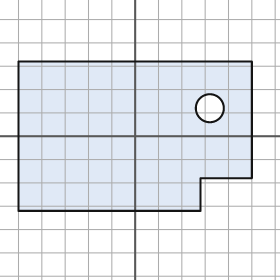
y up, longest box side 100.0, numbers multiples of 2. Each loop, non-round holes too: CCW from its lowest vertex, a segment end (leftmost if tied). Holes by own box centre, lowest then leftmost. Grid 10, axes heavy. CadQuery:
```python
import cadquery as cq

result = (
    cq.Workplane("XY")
    .moveTo(-50.0, -32.0)
    .lineTo(28.0, -32.0)
    .lineTo(28.0, -18.0)
    .lineTo(50.0, -18.0)
    .lineTo(50.0, 32.0)
    .lineTo(-50.0, 32.0)
    .close()
    .moveTo(32.0, 12.0)
    .circle(6.0)
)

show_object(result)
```